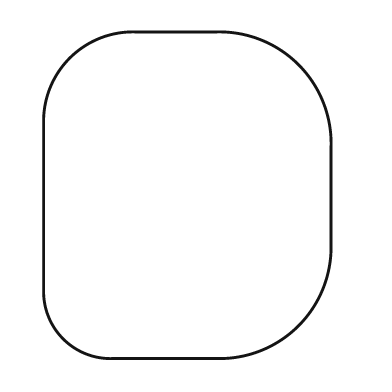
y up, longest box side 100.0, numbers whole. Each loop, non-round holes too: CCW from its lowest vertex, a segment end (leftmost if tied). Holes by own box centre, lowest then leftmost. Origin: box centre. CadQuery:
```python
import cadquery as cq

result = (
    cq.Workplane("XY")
    .moveTo(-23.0, -50.0)
    .lineTo(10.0, -50.0)
    .threePointArc((34.0, -40.0), (44.0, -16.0))
    .lineTo(44.0, 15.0)
    .threePointArc((34.0, 40.0), (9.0, 50.0))
    .lineTo(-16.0, 50.0)
    .threePointArc((-36.0, 42.0), (-44.0, 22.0))
    .lineTo(-44.0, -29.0)
    .threePointArc((-38.0, -44.0), (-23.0, -50.0))
    .close()
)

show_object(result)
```